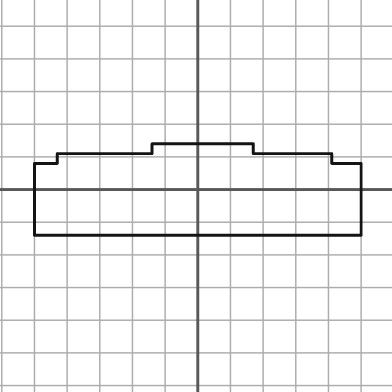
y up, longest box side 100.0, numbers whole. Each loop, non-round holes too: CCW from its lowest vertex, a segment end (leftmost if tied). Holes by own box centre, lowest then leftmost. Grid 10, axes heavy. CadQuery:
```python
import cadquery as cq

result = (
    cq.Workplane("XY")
    .moveTo(-50.0, -14.0)
    .lineTo(50.0, -14.0)
    .lineTo(50.0, 8.0)
    .lineTo(41.0, 8.0)
    .lineTo(41.0, 11.0)
    .lineTo(17.0, 11.0)
    .lineTo(17.0, 14.0)
    .lineTo(-14.0, 14.0)
    .lineTo(-14.0, 11.0)
    .lineTo(-43.0, 11.0)
    .lineTo(-43.0, 8.0)
    .lineTo(-50.0, 8.0)
    .close()
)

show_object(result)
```